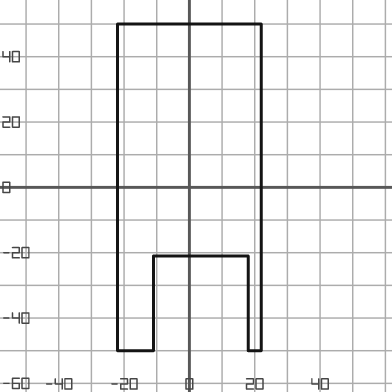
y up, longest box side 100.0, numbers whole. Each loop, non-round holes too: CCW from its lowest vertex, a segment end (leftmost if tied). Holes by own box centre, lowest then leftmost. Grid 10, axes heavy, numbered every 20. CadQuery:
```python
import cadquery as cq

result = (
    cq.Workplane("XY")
    .moveTo(-22.0, -50.0)
    .lineTo(-11.0, -50.0)
    .lineTo(-11.0, -21.0)
    .lineTo(18.0, -21.0)
    .lineTo(18.0, -50.0)
    .lineTo(22.0, -50.0)
    .lineTo(22.0, 50.0)
    .lineTo(-22.0, 50.0)
    .close()
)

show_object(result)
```